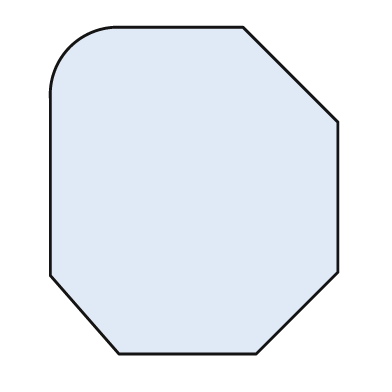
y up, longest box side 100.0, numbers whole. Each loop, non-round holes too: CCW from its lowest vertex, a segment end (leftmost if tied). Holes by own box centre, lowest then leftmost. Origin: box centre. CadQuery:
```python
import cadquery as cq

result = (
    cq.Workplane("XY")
    .moveTo(-23.0, -50.0)
    .lineTo(19.0, -50.0)
    .lineTo(44.0, -25.0)
    .lineTo(44.0, 21.0)
    .lineTo(15.0, 50.0)
    .lineTo(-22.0, 50.0)
    .threePointArc((-38.0, 44.0), (-44.0, 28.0))
    .lineTo(-44.0, -26.0)
    .close()
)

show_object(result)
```